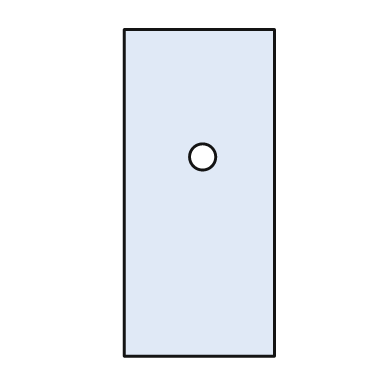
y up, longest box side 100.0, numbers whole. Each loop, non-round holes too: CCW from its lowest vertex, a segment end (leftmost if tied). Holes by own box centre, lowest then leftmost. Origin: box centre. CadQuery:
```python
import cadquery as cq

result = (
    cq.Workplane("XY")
    .moveTo(-23.0, -50.0)
    .lineTo(23.0, -50.0)
    .lineTo(23.0, 50.0)
    .lineTo(-23.0, 50.0)
    .close()
    .moveTo(1.0, 11.0)
    .circle(4.0)
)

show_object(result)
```